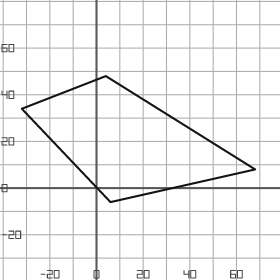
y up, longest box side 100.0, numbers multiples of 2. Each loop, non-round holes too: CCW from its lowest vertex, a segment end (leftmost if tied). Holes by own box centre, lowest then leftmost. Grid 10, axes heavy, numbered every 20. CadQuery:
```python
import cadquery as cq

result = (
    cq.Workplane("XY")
    .moveTo(6.0, -6.0)
    .lineTo(68.0, 8.0)
    .lineTo(4.0, 48.0)
    .lineTo(-32.0, 34.0)
    .close()
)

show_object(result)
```